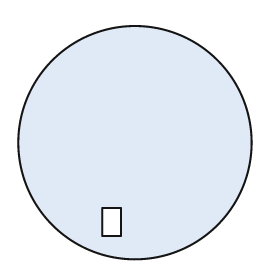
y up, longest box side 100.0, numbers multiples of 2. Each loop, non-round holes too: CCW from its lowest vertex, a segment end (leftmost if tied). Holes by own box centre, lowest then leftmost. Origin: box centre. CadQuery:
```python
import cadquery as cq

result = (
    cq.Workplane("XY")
    .moveTo(0.0, 0.0)
    .circle(50.0)
    .moveTo(-14.0, -40.0)
    .lineTo(-6.0, -40.0)
    .lineTo(-6.0, -28.0)
    .lineTo(-14.0, -28.0)
    .close()
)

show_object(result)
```